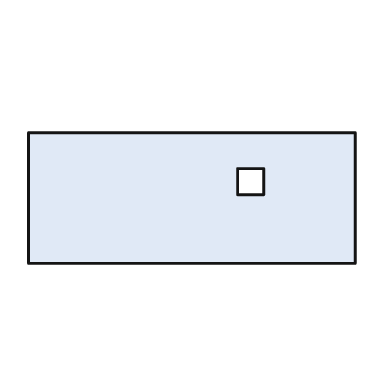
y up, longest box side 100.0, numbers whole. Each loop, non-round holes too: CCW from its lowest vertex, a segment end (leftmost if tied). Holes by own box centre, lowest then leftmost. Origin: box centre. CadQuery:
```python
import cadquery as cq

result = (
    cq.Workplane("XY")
    .moveTo(-50.0, -20.0)
    .lineTo(50.0, -20.0)
    .lineTo(50.0, 20.0)
    .lineTo(-50.0, 20.0)
    .close()
    .moveTo(14.0, 1.0)
    .lineTo(22.0, 1.0)
    .lineTo(22.0, 9.0)
    .lineTo(14.0, 9.0)
    .close()
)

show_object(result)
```